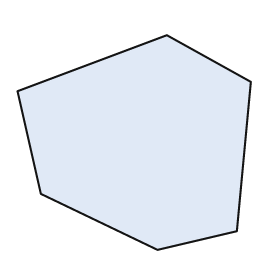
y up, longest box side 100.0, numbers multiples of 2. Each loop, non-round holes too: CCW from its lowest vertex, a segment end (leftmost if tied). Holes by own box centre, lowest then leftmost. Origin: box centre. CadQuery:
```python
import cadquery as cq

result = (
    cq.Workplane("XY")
    .moveTo(10.0, -46.0)
    .lineTo(44.0, -38.0)
    .lineTo(50.0, 26.0)
    .lineTo(14.0, 46.0)
    .lineTo(-50.0, 22.0)
    .lineTo(-40.0, -22.0)
    .close()
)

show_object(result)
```